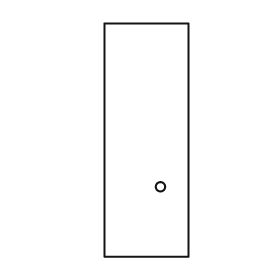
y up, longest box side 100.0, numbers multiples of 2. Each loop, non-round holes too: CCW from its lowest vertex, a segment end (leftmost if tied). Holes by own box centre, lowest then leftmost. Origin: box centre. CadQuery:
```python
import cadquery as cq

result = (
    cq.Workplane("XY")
    .moveTo(-18.0, -50.0)
    .lineTo(18.0, -50.0)
    .lineTo(18.0, 50.0)
    .lineTo(-18.0, 50.0)
    .close()
    .moveTo(6.0, -20.0)
    .circle(2.0)
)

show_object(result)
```